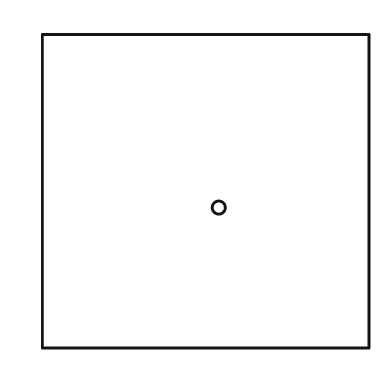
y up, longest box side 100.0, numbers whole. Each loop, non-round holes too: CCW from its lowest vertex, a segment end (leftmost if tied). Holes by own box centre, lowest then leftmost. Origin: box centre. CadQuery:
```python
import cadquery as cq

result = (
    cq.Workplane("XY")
    .moveTo(-50.0, -48.0)
    .lineTo(50.0, -48.0)
    .lineTo(50.0, 48.0)
    .lineTo(-50.0, 48.0)
    .close()
    .moveTo(4.0, -5.0)
    .circle(2.0)
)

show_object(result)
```